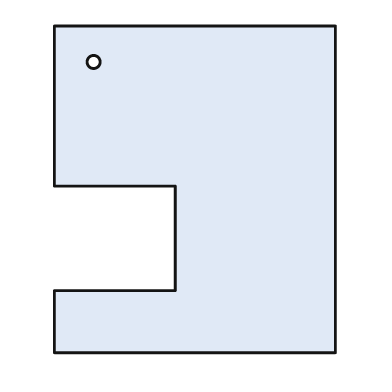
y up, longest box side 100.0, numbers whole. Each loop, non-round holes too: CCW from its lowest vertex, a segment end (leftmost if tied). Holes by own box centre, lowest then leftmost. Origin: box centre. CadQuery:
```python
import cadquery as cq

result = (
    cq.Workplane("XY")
    .moveTo(-43.0, -50.0)
    .lineTo(43.0, -50.0)
    .lineTo(43.0, 50.0)
    .lineTo(-43.0, 50.0)
    .lineTo(-43.0, 1.0)
    .lineTo(-6.0, 1.0)
    .lineTo(-6.0, -31.0)
    .lineTo(-43.0, -31.0)
    .close()
    .moveTo(-31.0, 39.0)
    .circle(2.0)
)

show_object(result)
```